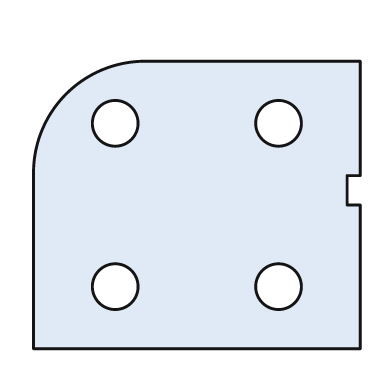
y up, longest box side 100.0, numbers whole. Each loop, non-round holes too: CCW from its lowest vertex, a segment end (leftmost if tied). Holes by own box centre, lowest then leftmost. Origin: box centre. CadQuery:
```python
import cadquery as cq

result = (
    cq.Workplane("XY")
    .moveTo(-50.0, -44.0)
    .lineTo(50.0, -44.0)
    .lineTo(50.0, 0.0)
    .lineTo(46.0, 0.0)
    .lineTo(46.0, 9.0)
    .lineTo(50.0, 9.0)
    .lineTo(50.0, 44.0)
    .lineTo(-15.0, 44.0)
    .threePointArc((-40.0, 34.0), (-50.0, 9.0))
    .close()
    .moveTo(-25.0, -25.0)
    .circle(7.0)
    .moveTo(25.0, -25.0)
    .circle(7.0)
    .moveTo(-25.0, 25.0)
    .circle(7.0)
    .moveTo(25.0, 25.0)
    .circle(7.0)
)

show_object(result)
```